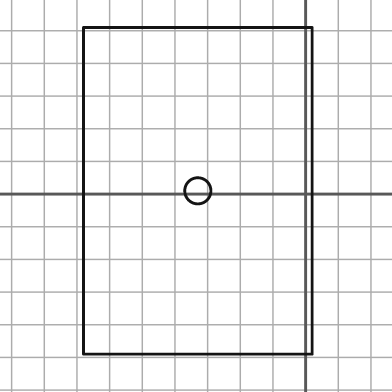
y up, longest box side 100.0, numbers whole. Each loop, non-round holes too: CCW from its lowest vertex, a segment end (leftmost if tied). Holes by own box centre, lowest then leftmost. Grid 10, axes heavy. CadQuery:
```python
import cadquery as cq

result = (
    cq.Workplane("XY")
    .moveTo(-68.0, -49.0)
    .lineTo(2.0, -49.0)
    .lineTo(2.0, 51.0)
    .lineTo(-68.0, 51.0)
    .close()
    .moveTo(-33.0, 1.0)
    .circle(4.0)
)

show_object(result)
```